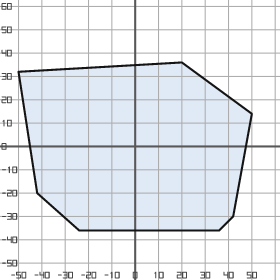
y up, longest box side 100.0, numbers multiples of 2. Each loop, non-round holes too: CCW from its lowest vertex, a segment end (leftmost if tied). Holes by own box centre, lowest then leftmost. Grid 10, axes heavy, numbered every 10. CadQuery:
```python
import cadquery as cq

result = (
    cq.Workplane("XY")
    .moveTo(-24.0, -36.0)
    .lineTo(36.0, -36.0)
    .lineTo(42.0, -30.0)
    .lineTo(50.0, 14.0)
    .lineTo(20.0, 36.0)
    .lineTo(-50.0, 32.0)
    .lineTo(-42.0, -20.0)
    .close()
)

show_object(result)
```